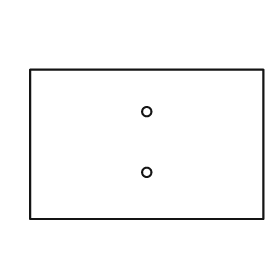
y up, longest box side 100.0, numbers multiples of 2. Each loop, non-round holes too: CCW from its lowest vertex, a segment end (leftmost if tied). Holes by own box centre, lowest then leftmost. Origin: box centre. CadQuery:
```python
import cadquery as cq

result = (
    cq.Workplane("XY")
    .moveTo(-50.0, -32.0)
    .lineTo(50.0, -32.0)
    .lineTo(50.0, 32.0)
    .lineTo(-50.0, 32.0)
    .close()
    .moveTo(0.0, -12.0)
    .circle(2.0)
    .moveTo(0.0, 14.0)
    .circle(2.0)
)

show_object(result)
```